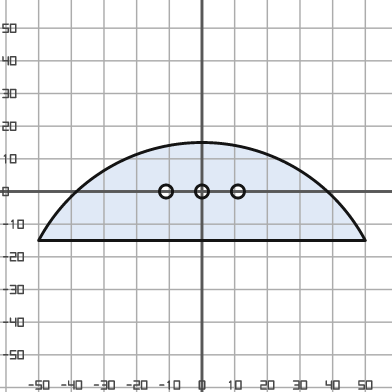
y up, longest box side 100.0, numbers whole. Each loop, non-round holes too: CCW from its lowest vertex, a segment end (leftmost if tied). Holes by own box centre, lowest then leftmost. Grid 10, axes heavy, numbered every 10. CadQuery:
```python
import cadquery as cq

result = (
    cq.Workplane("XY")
    .moveTo(-50.0, -15.0)
    .lineTo(50.0, -15.0)
    .threePointArc((0.0, 15.0), (-50.0, -15.0))
    .close()
    .moveTo(-11.0, 0.0)
    .circle(2.0)
    .moveTo(0.0, 0.0)
    .circle(2.0)
    .moveTo(11.0, 0.0)
    .circle(2.0)
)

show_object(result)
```